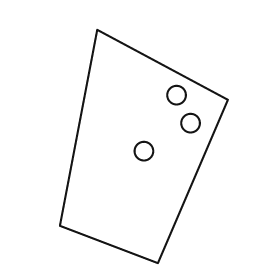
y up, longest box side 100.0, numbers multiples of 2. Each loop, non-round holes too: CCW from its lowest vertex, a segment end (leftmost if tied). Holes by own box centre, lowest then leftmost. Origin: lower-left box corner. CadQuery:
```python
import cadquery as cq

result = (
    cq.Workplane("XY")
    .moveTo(42.0, 0.0)
    .lineTo(72.0, 70.0)
    .lineTo(16.0, 100.0)
    .lineTo(0.0, 16.0)
    .close()
    .moveTo(36.0, 48.0)
    .circle(4.0)
    .moveTo(56.0, 60.0)
    .circle(4.0)
    .moveTo(50.0, 72.0)
    .circle(4.0)
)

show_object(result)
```